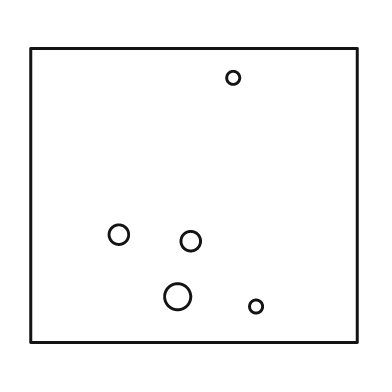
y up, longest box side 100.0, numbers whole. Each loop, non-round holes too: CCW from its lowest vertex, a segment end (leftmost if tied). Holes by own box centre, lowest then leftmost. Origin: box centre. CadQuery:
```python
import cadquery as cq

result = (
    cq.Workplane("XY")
    .moveTo(-50.0, -45.0)
    .lineTo(50.0, -45.0)
    .lineTo(50.0, 45.0)
    .lineTo(-50.0, 45.0)
    .close()
    .moveTo(19.0, -34.0)
    .circle(2.0)
    .moveTo(-5.0, -31.0)
    .circle(4.0)
    .moveTo(-1.0, -14.0)
    .circle(3.0)
    .moveTo(-23.0, -12.0)
    .circle(3.0)
    .moveTo(12.0, 36.0)
    .circle(2.0)
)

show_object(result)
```